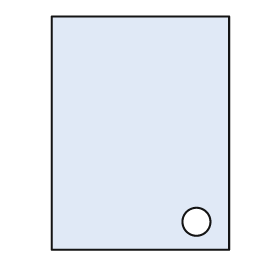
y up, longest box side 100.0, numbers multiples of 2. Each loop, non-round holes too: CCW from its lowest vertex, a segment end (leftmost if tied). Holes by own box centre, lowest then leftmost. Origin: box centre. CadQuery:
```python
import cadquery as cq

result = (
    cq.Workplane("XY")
    .moveTo(-38.0, -50.0)
    .lineTo(38.0, -50.0)
    .lineTo(38.0, 50.0)
    .lineTo(-38.0, 50.0)
    .close()
    .moveTo(24.0, -38.0)
    .circle(6.0)
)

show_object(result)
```